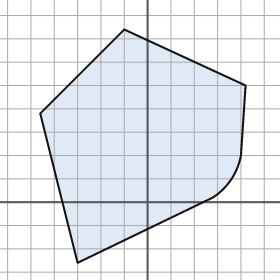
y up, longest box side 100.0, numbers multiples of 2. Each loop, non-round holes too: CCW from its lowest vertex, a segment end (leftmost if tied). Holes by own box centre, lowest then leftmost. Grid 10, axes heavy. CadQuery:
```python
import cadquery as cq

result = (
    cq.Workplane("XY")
    .moveTo(-30.0, -26.0)
    .lineTo(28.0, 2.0)
    .threePointArc((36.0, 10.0), (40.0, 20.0))
    .lineTo(42.0, 50.0)
    .lineTo(-10.0, 74.0)
    .lineTo(-46.0, 38.0)
    .close()
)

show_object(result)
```